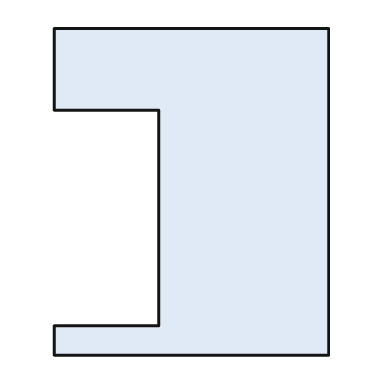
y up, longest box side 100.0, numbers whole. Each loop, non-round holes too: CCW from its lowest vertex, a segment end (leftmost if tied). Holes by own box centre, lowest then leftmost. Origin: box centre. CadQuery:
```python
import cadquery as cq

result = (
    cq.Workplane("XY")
    .moveTo(-42.0, -50.0)
    .lineTo(42.0, -50.0)
    .lineTo(42.0, 50.0)
    .lineTo(-42.0, 50.0)
    .lineTo(-42.0, 25.0)
    .lineTo(-10.0, 25.0)
    .lineTo(-10.0, -41.0)
    .lineTo(-42.0, -41.0)
    .close()
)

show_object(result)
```